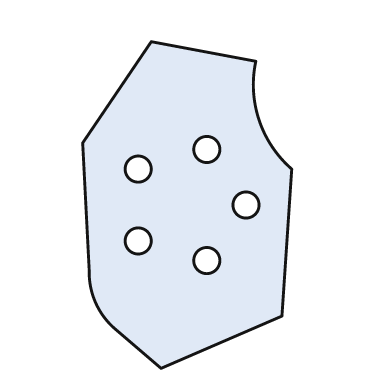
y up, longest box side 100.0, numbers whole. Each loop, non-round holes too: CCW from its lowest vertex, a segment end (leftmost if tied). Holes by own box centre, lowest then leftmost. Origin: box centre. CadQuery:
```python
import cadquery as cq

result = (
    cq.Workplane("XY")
    .moveTo(-8.0, -50.0)
    .lineTo(29.0, -34.0)
    .lineTo(32.0, 11.0)
    .threePointArc((22.0, 26.0), (21.0, 44.0))
    .lineTo(-11.0, 50.0)
    .lineTo(-32.0, 19.0)
    .lineTo(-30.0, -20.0)
    .threePointArc((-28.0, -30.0), (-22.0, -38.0))
    .close()
    .moveTo(6.0, -17.0)
    .circle(4.0)
    .moveTo(-15.0, -11.0)
    .circle(4.0)
    .moveTo(18.0, 0.0)
    .circle(4.0)
    .moveTo(-15.0, 11.0)
    .circle(4.0)
    .moveTo(6.0, 17.0)
    .circle(4.0)
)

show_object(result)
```